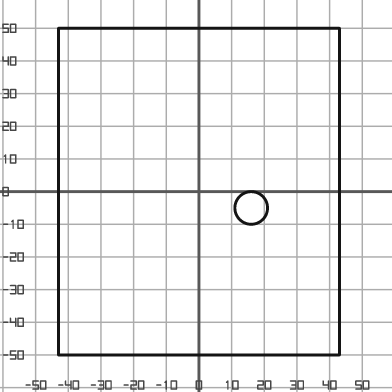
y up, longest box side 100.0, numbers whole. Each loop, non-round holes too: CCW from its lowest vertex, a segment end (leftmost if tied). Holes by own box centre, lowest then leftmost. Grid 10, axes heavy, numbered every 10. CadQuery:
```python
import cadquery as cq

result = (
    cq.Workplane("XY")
    .moveTo(-43.0, -50.0)
    .lineTo(43.0, -50.0)
    .lineTo(43.0, 50.0)
    .lineTo(-43.0, 50.0)
    .close()
    .moveTo(16.0, -5.0)
    .circle(5.0)
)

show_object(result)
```